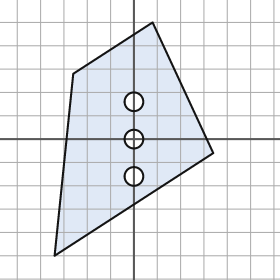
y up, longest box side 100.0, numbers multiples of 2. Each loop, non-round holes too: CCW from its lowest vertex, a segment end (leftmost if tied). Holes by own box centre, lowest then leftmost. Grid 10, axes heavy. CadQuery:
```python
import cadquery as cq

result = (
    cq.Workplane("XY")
    .moveTo(-34.0, -50.0)
    .lineTo(34.0, -6.0)
    .lineTo(8.0, 50.0)
    .lineTo(-26.0, 28.0)
    .close()
    .moveTo(0.0, -16.0)
    .circle(4.0)
    .moveTo(0.0, 0.0)
    .circle(4.0)
    .moveTo(0.0, 16.0)
    .circle(4.0)
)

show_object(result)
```